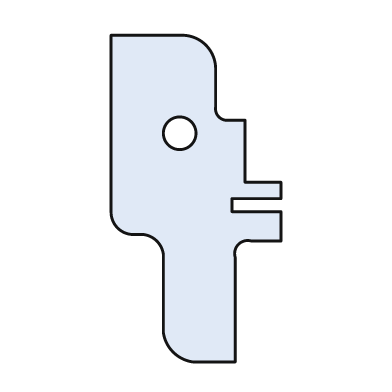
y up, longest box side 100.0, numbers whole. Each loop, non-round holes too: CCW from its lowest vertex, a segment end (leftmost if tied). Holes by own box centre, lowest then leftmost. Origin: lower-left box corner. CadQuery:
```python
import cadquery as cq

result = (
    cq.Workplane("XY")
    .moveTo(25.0, 0.0)
    .lineTo(38.0, 0.0)
    .lineTo(38.0, 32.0)
    .threePointArc((39.0, 36.0), (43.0, 37.0))
    .lineTo(52.0, 37.0)
    .lineTo(52.0, 46.0)
    .lineTo(37.0, 46.0)
    .lineTo(37.0, 50.0)
    .lineTo(52.0, 50.0)
    .lineTo(52.0, 55.0)
    .lineTo(41.0, 55.0)
    .lineTo(41.0, 74.0)
    .lineTo(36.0, 74.0)
    .threePointArc((33.0, 75.0), (32.0, 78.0))
    .lineTo(32.0, 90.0)
    .threePointArc((29.0, 97.0), (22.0, 100.0))
    .lineTo(0.0, 100.0)
    .lineTo(0.0, 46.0)
    .threePointArc((2.0, 41.0), (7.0, 39.0))
    .lineTo(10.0, 39.0)
    .threePointArc((14.0, 37.0), (16.0, 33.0))
    .lineTo(16.0, 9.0)
    .threePointArc((19.0, 3.0), (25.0, 0.0))
    .close()
    .moveTo(21.0, 70.0)
    .circle(5.0)
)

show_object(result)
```